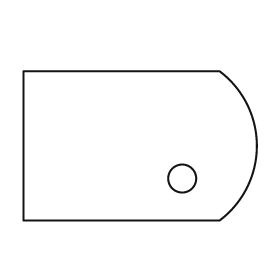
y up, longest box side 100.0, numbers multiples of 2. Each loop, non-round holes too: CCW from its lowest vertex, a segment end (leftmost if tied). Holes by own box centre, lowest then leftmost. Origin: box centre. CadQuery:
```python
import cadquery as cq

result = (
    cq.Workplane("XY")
    .moveTo(-50.0, -32.0)
    .lineTo(34.0, -32.0)
    .threePointArc((50.0, 0.0), (34.0, 32.0))
    .lineTo(-50.0, 32.0)
    .close()
    .moveTo(18.0, -14.0)
    .circle(6.0)
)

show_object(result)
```